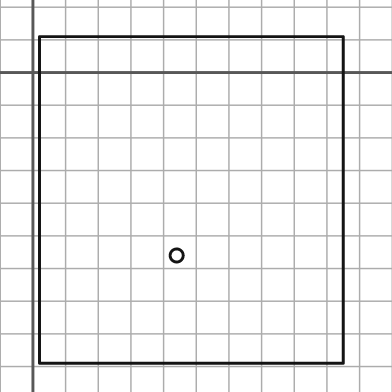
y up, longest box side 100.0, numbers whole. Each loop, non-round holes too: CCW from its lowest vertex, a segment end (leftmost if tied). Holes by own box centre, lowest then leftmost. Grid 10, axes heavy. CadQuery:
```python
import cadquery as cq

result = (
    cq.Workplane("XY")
    .moveTo(2.0, -89.0)
    .lineTo(95.0, -89.0)
    .lineTo(95.0, 11.0)
    .lineTo(2.0, 11.0)
    .close()
    .moveTo(44.0, -56.0)
    .circle(2.0)
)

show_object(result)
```